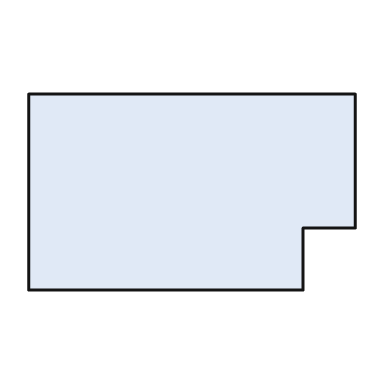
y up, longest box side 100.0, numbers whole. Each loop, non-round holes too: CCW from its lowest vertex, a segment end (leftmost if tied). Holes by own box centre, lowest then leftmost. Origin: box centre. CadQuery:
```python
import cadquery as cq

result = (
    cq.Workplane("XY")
    .moveTo(-50.0, -30.0)
    .lineTo(34.0, -30.0)
    .lineTo(34.0, -11.0)
    .lineTo(50.0, -11.0)
    .lineTo(50.0, 30.0)
    .lineTo(-50.0, 30.0)
    .close()
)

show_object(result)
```